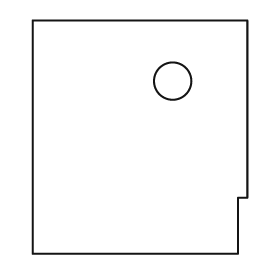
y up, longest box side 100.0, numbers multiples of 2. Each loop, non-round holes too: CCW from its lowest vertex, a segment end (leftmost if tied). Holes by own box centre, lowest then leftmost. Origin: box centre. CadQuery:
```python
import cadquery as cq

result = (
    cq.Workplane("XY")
    .moveTo(-46.0, -50.0)
    .lineTo(42.0, -50.0)
    .lineTo(42.0, -26.0)
    .lineTo(46.0, -26.0)
    .lineTo(46.0, 50.0)
    .lineTo(-46.0, 50.0)
    .close()
    .moveTo(14.0, 24.0)
    .circle(8.0)
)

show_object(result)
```